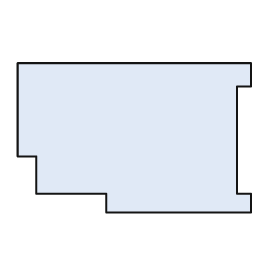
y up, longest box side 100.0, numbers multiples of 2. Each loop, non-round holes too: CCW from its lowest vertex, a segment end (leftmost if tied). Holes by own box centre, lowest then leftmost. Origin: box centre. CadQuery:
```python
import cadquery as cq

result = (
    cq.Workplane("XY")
    .moveTo(-12.0, -32.0)
    .lineTo(50.0, -32.0)
    .lineTo(50.0, -24.0)
    .lineTo(44.0, -24.0)
    .lineTo(44.0, 22.0)
    .lineTo(50.0, 22.0)
    .lineTo(50.0, 32.0)
    .lineTo(-50.0, 32.0)
    .lineTo(-50.0, -8.0)
    .lineTo(-42.0, -8.0)
    .lineTo(-42.0, -24.0)
    .lineTo(-12.0, -24.0)
    .close()
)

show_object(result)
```